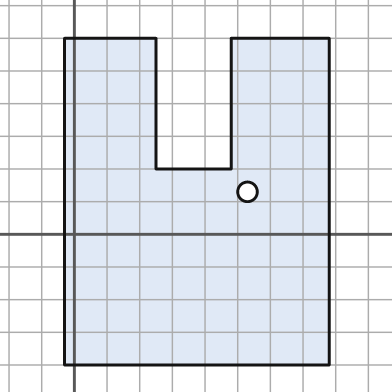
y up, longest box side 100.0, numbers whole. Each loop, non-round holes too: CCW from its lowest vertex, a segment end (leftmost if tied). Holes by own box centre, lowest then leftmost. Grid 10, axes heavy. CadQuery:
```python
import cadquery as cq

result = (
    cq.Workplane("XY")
    .moveTo(-3.0, -40.0)
    .lineTo(78.0, -40.0)
    .lineTo(78.0, 60.0)
    .lineTo(48.0, 60.0)
    .lineTo(48.0, 20.0)
    .lineTo(25.0, 20.0)
    .lineTo(25.0, 60.0)
    .lineTo(-3.0, 60.0)
    .close()
    .moveTo(53.0, 13.0)
    .circle(3.0)
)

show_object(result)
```